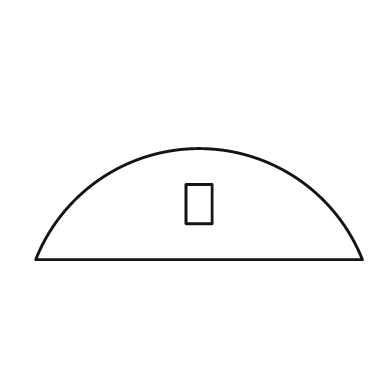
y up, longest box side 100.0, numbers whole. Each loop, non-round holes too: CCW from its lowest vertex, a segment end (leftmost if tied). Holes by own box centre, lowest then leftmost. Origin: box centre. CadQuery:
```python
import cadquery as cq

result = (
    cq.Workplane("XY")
    .moveTo(-50.0, -17.0)
    .lineTo(50.0, -17.0)
    .threePointArc((0.0, 17.0), (-50.0, -17.0))
    .close()
    .moveTo(-4.0, -6.0)
    .lineTo(4.0, -6.0)
    .lineTo(4.0, 6.0)
    .lineTo(-4.0, 6.0)
    .close()
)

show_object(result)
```